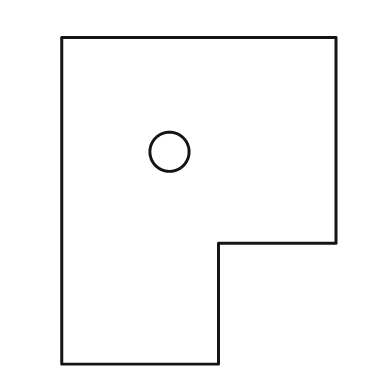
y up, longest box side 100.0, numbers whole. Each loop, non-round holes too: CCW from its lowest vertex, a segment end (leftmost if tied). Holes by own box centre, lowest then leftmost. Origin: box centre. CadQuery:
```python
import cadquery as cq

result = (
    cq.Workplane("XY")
    .moveTo(-42.0, -50.0)
    .lineTo(6.0, -50.0)
    .lineTo(6.0, -13.0)
    .lineTo(42.0, -13.0)
    .lineTo(42.0, 50.0)
    .lineTo(-42.0, 50.0)
    .close()
    .moveTo(-9.0, 15.0)
    .circle(6.0)
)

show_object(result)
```